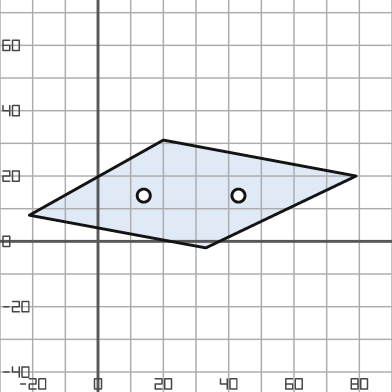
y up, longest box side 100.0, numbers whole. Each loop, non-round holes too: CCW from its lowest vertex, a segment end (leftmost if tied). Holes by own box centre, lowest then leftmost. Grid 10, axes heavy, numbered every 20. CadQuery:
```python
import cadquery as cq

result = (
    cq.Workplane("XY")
    .moveTo(33.0, -2.0)
    .lineTo(79.0, 20.0)
    .lineTo(20.0, 31.0)
    .lineTo(-21.0, 8.0)
    .close()
    .moveTo(14.0, 14.0)
    .circle(2.0)
    .moveTo(43.0, 14.0)
    .circle(2.0)
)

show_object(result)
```